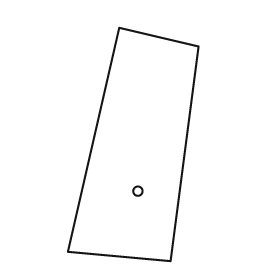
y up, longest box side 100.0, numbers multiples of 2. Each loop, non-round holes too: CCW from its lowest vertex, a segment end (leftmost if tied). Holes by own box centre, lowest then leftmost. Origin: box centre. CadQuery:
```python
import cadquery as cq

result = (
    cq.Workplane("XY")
    .moveTo(16.0, -50.0)
    .lineTo(28.0, 42.0)
    .lineTo(-6.0, 50.0)
    .lineTo(-28.0, -46.0)
    .close()
    .moveTo(2.0, -20.0)
    .circle(2.0)
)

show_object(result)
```